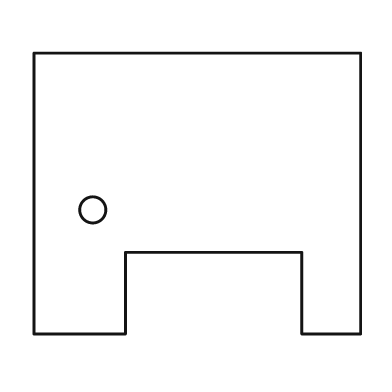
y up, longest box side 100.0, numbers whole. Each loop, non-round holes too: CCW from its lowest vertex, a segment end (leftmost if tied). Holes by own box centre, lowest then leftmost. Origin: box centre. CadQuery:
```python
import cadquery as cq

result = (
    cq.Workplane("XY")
    .moveTo(-50.0, -43.0)
    .lineTo(-22.0, -43.0)
    .lineTo(-22.0, -18.0)
    .lineTo(32.0, -18.0)
    .lineTo(32.0, -43.0)
    .lineTo(50.0, -43.0)
    .lineTo(50.0, 43.0)
    .lineTo(-50.0, 43.0)
    .close()
    .moveTo(-32.0, -5.0)
    .circle(4.0)
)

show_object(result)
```